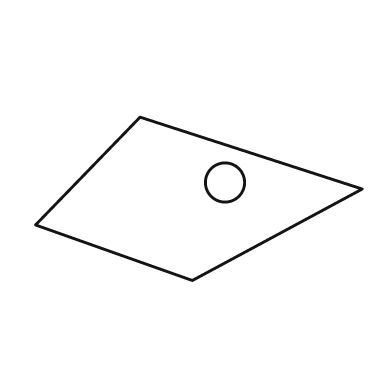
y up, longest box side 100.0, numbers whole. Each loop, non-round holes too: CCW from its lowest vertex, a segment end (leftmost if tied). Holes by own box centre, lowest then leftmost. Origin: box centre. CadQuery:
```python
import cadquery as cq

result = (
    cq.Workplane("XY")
    .moveTo(-2.0, -25.0)
    .lineTo(50.0, 3.0)
    .lineTo(-18.0, 25.0)
    .lineTo(-50.0, -8.0)
    .close()
    .moveTo(8.0, 5.0)
    .circle(6.0)
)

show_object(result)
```